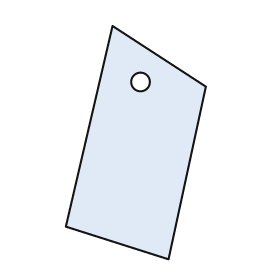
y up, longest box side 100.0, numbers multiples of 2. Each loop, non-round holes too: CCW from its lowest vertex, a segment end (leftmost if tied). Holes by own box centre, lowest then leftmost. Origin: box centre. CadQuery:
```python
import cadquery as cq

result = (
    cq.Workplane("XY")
    .moveTo(14.0, -50.0)
    .lineTo(30.0, 24.0)
    .lineTo(-10.0, 50.0)
    .lineTo(-30.0, -36.0)
    .close()
    .moveTo(2.0, 26.0)
    .circle(4.0)
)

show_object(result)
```